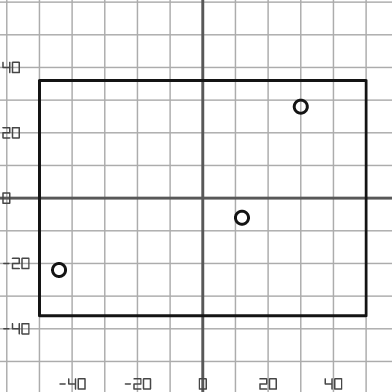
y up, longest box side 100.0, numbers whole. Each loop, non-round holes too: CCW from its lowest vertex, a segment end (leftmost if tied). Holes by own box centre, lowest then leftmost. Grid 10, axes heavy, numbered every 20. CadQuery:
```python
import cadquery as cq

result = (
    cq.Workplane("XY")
    .moveTo(-50.0, -36.0)
    .lineTo(50.0, -36.0)
    .lineTo(50.0, 36.0)
    .lineTo(-50.0, 36.0)
    .close()
    .moveTo(-44.0, -22.0)
    .circle(2.0)
    .moveTo(12.0, -6.0)
    .circle(2.0)
    .moveTo(30.0, 28.0)
    .circle(2.0)
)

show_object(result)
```